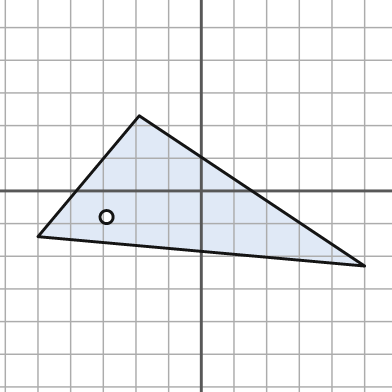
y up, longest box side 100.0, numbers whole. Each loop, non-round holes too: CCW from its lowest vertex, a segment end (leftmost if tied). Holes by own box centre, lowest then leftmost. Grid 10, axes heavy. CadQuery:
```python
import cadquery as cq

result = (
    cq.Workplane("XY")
    .moveTo(50.0, -23.0)
    .lineTo(-19.0, 23.0)
    .lineTo(-50.0, -14.0)
    .close()
    .moveTo(-29.0, -8.0)
    .circle(2.0)
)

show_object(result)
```